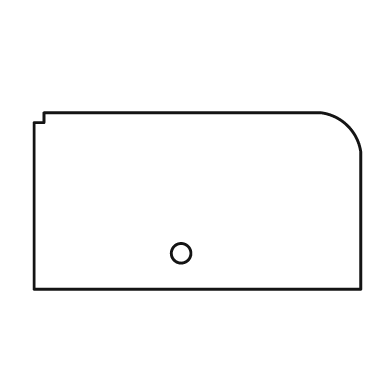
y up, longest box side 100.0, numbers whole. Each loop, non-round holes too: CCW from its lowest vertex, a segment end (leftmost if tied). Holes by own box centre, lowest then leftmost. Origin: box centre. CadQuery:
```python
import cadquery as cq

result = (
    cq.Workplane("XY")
    .moveTo(-50.0, -27.0)
    .lineTo(50.0, -27.0)
    .lineTo(50.0, 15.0)
    .threePointArc((46.0, 23.0), (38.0, 27.0))
    .lineTo(-47.0, 27.0)
    .lineTo(-47.0, 24.0)
    .lineTo(-50.0, 24.0)
    .close()
    .moveTo(-5.0, -16.0)
    .circle(3.0)
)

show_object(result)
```